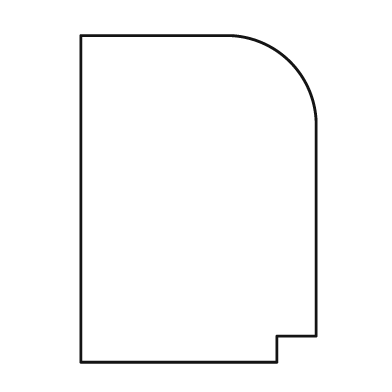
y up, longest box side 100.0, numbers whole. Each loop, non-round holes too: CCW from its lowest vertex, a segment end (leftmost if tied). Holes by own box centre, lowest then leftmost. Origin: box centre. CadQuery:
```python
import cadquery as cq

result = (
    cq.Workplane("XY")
    .moveTo(-36.0, -50.0)
    .lineTo(24.0, -50.0)
    .lineTo(24.0, -42.0)
    .lineTo(36.0, -42.0)
    .lineTo(36.0, 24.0)
    .threePointArc((28.0, 42.0), (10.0, 50.0))
    .lineTo(-36.0, 50.0)
    .close()
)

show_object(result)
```